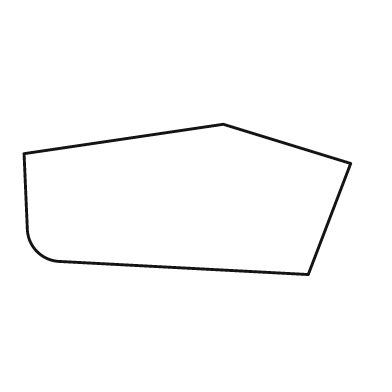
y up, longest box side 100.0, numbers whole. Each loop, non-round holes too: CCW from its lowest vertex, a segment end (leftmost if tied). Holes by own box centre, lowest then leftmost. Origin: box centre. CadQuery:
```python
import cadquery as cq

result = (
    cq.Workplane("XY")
    .moveTo(37.0, -23.0)
    .lineTo(50.0, 11.0)
    .lineTo(11.0, 23.0)
    .lineTo(-50.0, 14.0)
    .lineTo(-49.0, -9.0)
    .threePointArc((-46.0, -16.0), (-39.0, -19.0))
    .close()
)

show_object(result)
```